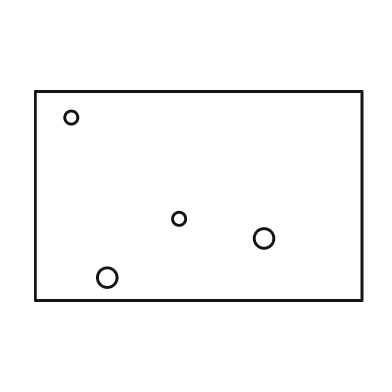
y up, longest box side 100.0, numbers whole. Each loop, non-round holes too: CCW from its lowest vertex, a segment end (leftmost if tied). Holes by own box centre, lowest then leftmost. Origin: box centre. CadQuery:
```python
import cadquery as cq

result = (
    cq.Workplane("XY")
    .moveTo(-50.0, -32.0)
    .lineTo(50.0, -32.0)
    .lineTo(50.0, 32.0)
    .lineTo(-50.0, 32.0)
    .close()
    .moveTo(-28.0, -25.0)
    .circle(3.0)
    .moveTo(20.0, -13.0)
    .circle(3.0)
    .moveTo(-6.0, -7.0)
    .circle(2.0)
    .moveTo(-39.0, 24.0)
    .circle(2.0)
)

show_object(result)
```